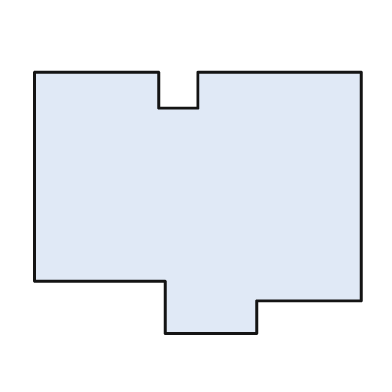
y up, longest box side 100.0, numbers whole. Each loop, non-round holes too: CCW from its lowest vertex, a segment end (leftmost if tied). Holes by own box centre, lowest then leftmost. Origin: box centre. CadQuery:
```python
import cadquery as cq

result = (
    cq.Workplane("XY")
    .moveTo(-10.0, -40.0)
    .lineTo(18.0, -40.0)
    .lineTo(18.0, -30.0)
    .lineTo(50.0, -30.0)
    .lineTo(50.0, 40.0)
    .lineTo(0.0, 40.0)
    .lineTo(0.0, 29.0)
    .lineTo(-12.0, 29.0)
    .lineTo(-12.0, 40.0)
    .lineTo(-50.0, 40.0)
    .lineTo(-50.0, -24.0)
    .lineTo(-10.0, -24.0)
    .close()
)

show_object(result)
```